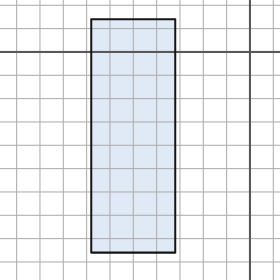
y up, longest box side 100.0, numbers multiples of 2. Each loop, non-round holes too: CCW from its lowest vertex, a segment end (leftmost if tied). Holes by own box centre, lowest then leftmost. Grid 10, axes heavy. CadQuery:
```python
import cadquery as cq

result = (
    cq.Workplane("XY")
    .moveTo(-68.0, -86.0)
    .lineTo(-32.0, -86.0)
    .lineTo(-32.0, 14.0)
    .lineTo(-68.0, 14.0)
    .close()
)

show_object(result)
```